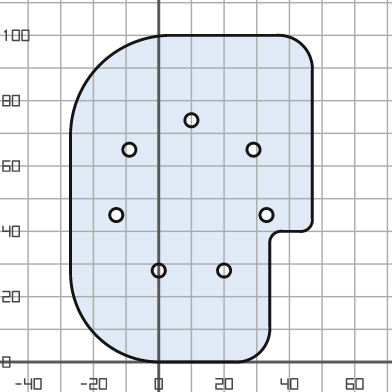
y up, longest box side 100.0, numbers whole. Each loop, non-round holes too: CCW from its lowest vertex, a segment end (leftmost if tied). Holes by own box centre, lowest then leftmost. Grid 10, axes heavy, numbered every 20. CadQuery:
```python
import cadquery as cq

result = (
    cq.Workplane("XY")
    .moveTo(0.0, 0.0)
    .lineTo(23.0, 0.0)
    .threePointArc((31.0, 3.0), (34.0, 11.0))
    .lineTo(34.0, 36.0)
    .threePointArc((35.0, 39.0), (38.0, 40.0))
    .lineTo(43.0, 40.0)
    .threePointArc((46.0, 41.0), (47.0, 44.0))
    .lineTo(47.0, 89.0)
    .threePointArc((44.0, 97.0), (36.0, 100.0))
    .lineTo(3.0, 100.0)
    .threePointArc((-18.0, 91.0), (-27.0, 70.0))
    .lineTo(-27.0, 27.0)
    .threePointArc((-19.0, 8.0), (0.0, 0.0))
    .close()
    .moveTo(0.0, 28.0)
    .circle(2.0)
    .moveTo(20.0, 28.0)
    .circle(2.0)
    .moveTo(-13.0, 45.0)
    .circle(2.0)
    .moveTo(33.0, 45.0)
    .circle(2.0)
    .moveTo(-9.0, 65.0)
    .circle(2.0)
    .moveTo(29.0, 65.0)
    .circle(2.0)
    .moveTo(10.0, 74.0)
    .circle(2.0)
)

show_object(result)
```